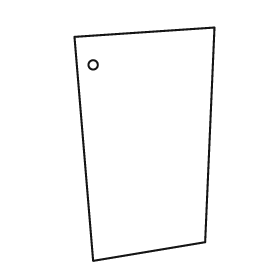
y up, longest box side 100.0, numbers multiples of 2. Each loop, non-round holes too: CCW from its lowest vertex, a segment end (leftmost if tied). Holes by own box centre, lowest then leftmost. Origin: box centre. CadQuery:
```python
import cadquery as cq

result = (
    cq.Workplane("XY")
    .moveTo(-22.0, -50.0)
    .lineTo(26.0, -42.0)
    .lineTo(30.0, 50.0)
    .lineTo(-30.0, 46.0)
    .close()
    .moveTo(-22.0, 34.0)
    .circle(2.0)
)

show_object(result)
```